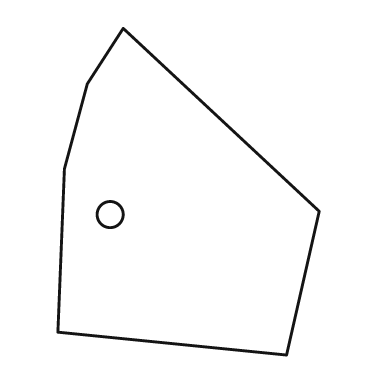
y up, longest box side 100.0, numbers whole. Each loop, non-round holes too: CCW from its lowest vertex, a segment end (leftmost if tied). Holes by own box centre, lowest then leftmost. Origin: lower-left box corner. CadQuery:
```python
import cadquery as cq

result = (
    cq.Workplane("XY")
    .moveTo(70.0, 0.0)
    .lineTo(80.0, 44.0)
    .lineTo(20.0, 100.0)
    .lineTo(9.0, 83.0)
    .lineTo(2.0, 57.0)
    .lineTo(0.0, 7.0)
    .close()
    .moveTo(16.0, 43.0)
    .circle(4.0)
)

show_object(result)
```